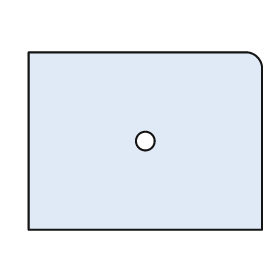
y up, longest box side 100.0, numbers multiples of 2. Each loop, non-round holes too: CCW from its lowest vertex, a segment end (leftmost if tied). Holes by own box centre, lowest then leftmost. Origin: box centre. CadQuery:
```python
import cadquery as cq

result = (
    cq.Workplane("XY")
    .moveTo(-50.0, -38.0)
    .lineTo(50.0, -38.0)
    .lineTo(50.0, 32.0)
    .threePointArc((48.0, 36.0), (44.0, 38.0))
    .lineTo(-50.0, 38.0)
    .close()
    .moveTo(0.0, 0.0)
    .circle(4.0)
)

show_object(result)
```